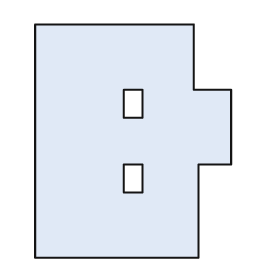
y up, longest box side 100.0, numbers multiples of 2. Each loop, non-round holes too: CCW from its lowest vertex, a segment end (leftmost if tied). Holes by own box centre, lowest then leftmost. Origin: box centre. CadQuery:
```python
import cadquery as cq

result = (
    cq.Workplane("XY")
    .moveTo(-42.0, -50.0)
    .lineTo(28.0, -50.0)
    .lineTo(28.0, -10.0)
    .lineTo(42.0, -10.0)
    .lineTo(42.0, 22.0)
    .lineTo(26.0, 22.0)
    .lineTo(26.0, 50.0)
    .lineTo(-42.0, 50.0)
    .close()
    .moveTo(-4.0, -22.0)
    .lineTo(4.0, -22.0)
    .lineTo(4.0, -10.0)
    .lineTo(-4.0, -10.0)
    .close()
    .moveTo(-4.0, 10.0)
    .lineTo(4.0, 10.0)
    .lineTo(4.0, 22.0)
    .lineTo(-4.0, 22.0)
    .close()
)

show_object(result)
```